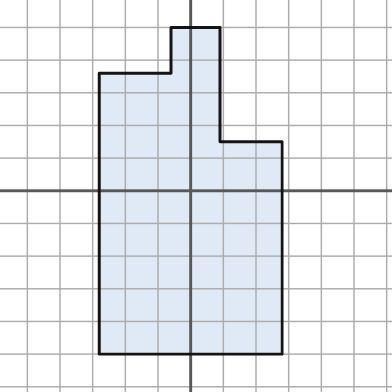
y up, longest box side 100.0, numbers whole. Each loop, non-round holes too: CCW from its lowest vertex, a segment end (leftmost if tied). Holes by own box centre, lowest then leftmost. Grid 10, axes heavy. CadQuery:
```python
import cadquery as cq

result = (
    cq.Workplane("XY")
    .moveTo(-28.0, -50.0)
    .lineTo(28.0, -50.0)
    .lineTo(28.0, 15.0)
    .lineTo(9.0, 15.0)
    .lineTo(9.0, 50.0)
    .lineTo(-6.0, 50.0)
    .lineTo(-6.0, 36.0)
    .lineTo(-28.0, 36.0)
    .close()
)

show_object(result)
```